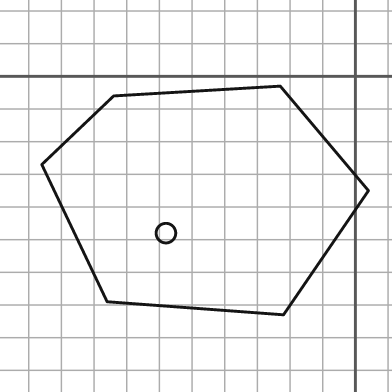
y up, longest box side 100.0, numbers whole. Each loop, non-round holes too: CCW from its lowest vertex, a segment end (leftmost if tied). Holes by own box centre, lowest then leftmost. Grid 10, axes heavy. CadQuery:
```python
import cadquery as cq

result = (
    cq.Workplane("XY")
    .moveTo(-22.0, -73.0)
    .lineTo(4.0, -35.0)
    .lineTo(-23.0, -3.0)
    .lineTo(-74.0, -6.0)
    .lineTo(-96.0, -27.0)
    .lineTo(-76.0, -69.0)
    .close()
    .moveTo(-58.0, -48.0)
    .circle(3.0)
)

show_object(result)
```